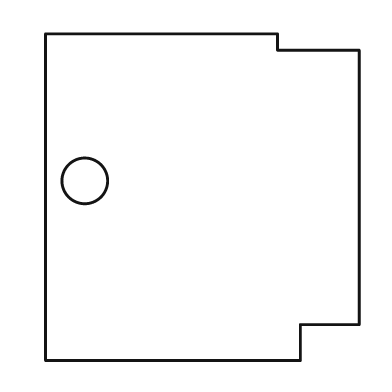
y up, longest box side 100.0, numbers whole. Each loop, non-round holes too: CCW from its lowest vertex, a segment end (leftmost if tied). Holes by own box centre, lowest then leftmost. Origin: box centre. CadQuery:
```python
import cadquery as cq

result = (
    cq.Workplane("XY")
    .moveTo(-48.0, -50.0)
    .lineTo(30.0, -50.0)
    .lineTo(30.0, -39.0)
    .lineTo(48.0, -39.0)
    .lineTo(48.0, 45.0)
    .lineTo(23.0, 45.0)
    .lineTo(23.0, 50.0)
    .lineTo(-48.0, 50.0)
    .close()
    .moveTo(-36.0, 5.0)
    .circle(7.0)
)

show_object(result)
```